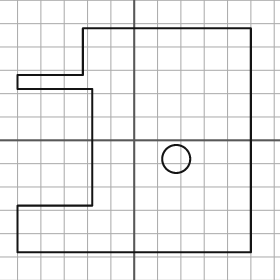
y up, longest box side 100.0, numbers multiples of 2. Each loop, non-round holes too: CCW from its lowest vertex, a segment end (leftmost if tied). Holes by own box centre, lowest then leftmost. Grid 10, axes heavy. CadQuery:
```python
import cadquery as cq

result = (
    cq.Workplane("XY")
    .moveTo(-50.0, -48.0)
    .lineTo(50.0, -48.0)
    .lineTo(50.0, 48.0)
    .lineTo(-22.0, 48.0)
    .lineTo(-22.0, 28.0)
    .lineTo(-50.0, 28.0)
    .lineTo(-50.0, 22.0)
    .lineTo(-18.0, 22.0)
    .lineTo(-18.0, -28.0)
    .lineTo(-50.0, -28.0)
    .close()
    .moveTo(18.0, -8.0)
    .circle(6.0)
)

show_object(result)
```